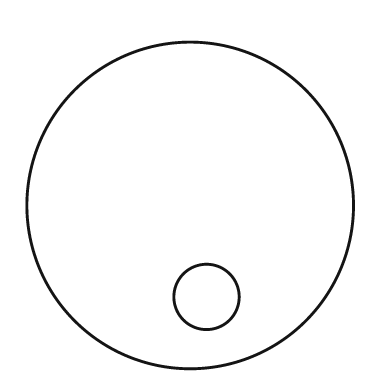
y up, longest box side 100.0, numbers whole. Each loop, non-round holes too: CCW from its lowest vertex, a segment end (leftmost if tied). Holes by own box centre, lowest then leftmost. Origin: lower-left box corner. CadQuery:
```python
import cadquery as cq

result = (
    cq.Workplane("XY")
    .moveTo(50.0, 50.0)
    .circle(50.0)
    .moveTo(55.0, 22.0)
    .circle(10.0)
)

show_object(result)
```